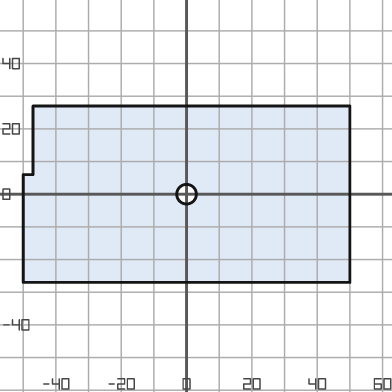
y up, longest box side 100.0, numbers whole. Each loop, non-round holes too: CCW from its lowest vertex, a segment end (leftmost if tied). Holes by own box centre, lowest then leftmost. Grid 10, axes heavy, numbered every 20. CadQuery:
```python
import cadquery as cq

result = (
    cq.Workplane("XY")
    .moveTo(-50.0, -27.0)
    .lineTo(50.0, -27.0)
    .lineTo(50.0, 27.0)
    .lineTo(-47.0, 27.0)
    .lineTo(-47.0, 6.0)
    .lineTo(-50.0, 6.0)
    .close()
    .moveTo(0.0, 0.0)
    .circle(3.0)
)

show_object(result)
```